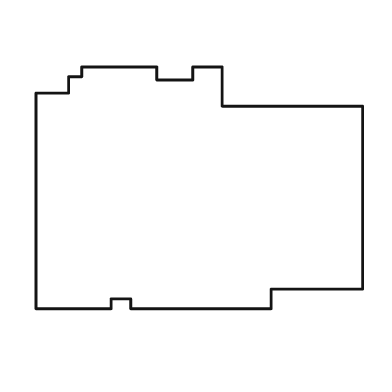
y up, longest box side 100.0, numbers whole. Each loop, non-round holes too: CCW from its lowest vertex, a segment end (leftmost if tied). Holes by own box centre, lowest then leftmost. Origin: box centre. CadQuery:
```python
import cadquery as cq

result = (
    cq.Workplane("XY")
    .moveTo(-50.0, -37.0)
    .lineTo(-27.0, -37.0)
    .lineTo(-27.0, -34.0)
    .lineTo(-21.0, -34.0)
    .lineTo(-21.0, -37.0)
    .lineTo(22.0, -37.0)
    .lineTo(22.0, -31.0)
    .lineTo(50.0, -31.0)
    .lineTo(50.0, 25.0)
    .lineTo(7.0, 25.0)
    .lineTo(7.0, 37.0)
    .lineTo(-2.0, 37.0)
    .lineTo(-2.0, 33.0)
    .lineTo(-13.0, 33.0)
    .lineTo(-13.0, 37.0)
    .lineTo(-36.0, 37.0)
    .lineTo(-36.0, 34.0)
    .lineTo(-40.0, 34.0)
    .lineTo(-40.0, 29.0)
    .lineTo(-50.0, 29.0)
    .close()
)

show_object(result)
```